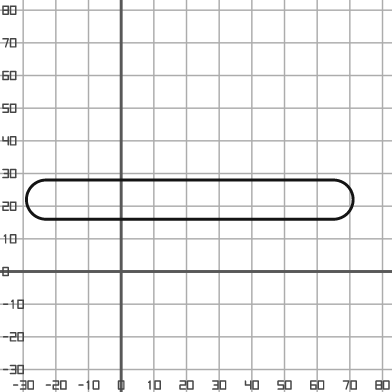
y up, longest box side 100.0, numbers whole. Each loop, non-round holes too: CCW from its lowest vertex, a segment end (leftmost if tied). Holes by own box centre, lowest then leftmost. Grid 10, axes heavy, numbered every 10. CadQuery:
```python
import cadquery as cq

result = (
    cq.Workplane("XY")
    .moveTo(-23.0, 16.0)
    .lineTo(65.0, 16.0)
    .threePointArc((71.0, 22.0), (65.0, 28.0))
    .lineTo(-23.0, 28.0)
    .threePointArc((-29.0, 22.0), (-23.0, 16.0))
    .close()
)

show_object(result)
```